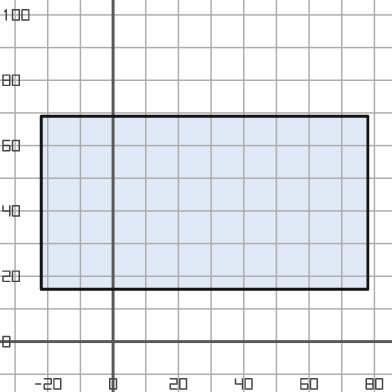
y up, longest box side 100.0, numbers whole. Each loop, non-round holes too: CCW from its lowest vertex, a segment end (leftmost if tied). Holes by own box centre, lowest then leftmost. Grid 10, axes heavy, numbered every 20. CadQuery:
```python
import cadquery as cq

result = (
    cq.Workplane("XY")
    .moveTo(-22.0, 16.0)
    .lineTo(78.0, 16.0)
    .lineTo(78.0, 69.0)
    .lineTo(-22.0, 69.0)
    .close()
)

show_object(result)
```